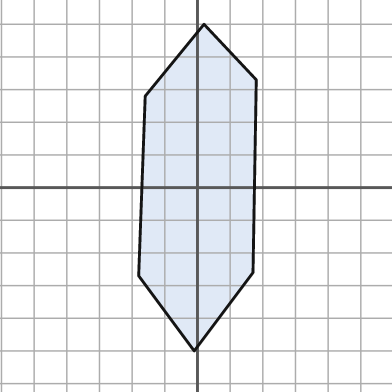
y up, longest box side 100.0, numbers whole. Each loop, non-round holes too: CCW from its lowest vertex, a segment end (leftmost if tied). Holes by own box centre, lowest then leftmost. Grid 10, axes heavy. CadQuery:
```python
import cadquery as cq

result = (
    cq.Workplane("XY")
    .moveTo(-1.0, -50.0)
    .lineTo(17.0, -26.0)
    .lineTo(18.0, 33.0)
    .lineTo(2.0, 50.0)
    .lineTo(-16.0, 28.0)
    .lineTo(-18.0, -27.0)
    .close()
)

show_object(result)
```